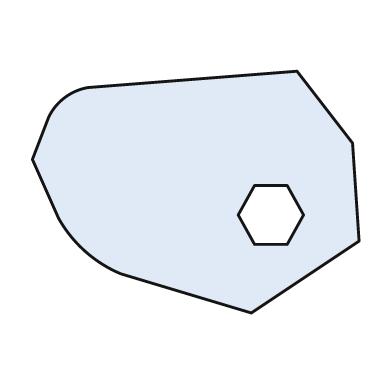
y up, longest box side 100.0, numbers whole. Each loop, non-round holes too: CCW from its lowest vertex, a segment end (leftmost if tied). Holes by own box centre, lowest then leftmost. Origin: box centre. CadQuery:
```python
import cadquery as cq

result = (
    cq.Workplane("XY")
    .moveTo(17.0, -37.0)
    .lineTo(50.0, -15.0)
    .lineTo(48.0, 15.0)
    .lineTo(31.0, 37.0)
    .lineTo(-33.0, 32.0)
    .threePointArc((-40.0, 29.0), (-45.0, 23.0))
    .lineTo(-50.0, 10.0)
    .lineTo(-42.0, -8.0)
    .threePointArc((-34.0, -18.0), (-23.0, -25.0))
    .close()
    .moveTo(18.0, -16.0)
    .lineTo(28.0, -16.0)
    .lineTo(33.0, -7.0)
    .lineTo(28.0, 2.0)
    .lineTo(18.0, 2.0)
    .lineTo(13.0, -7.0)
    .close()
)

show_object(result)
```